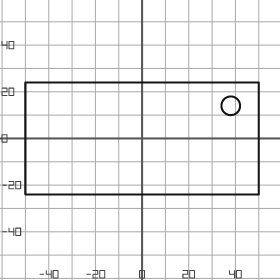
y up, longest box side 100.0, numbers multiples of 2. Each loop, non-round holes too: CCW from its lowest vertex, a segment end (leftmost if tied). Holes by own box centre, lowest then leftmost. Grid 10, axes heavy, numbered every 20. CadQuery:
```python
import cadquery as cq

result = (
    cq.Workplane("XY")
    .moveTo(-50.0, -24.0)
    .lineTo(50.0, -24.0)
    .lineTo(50.0, 24.0)
    .lineTo(-50.0, 24.0)
    .close()
    .moveTo(38.0, 14.0)
    .circle(4.0)
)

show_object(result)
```